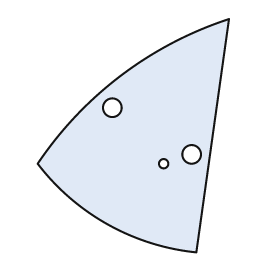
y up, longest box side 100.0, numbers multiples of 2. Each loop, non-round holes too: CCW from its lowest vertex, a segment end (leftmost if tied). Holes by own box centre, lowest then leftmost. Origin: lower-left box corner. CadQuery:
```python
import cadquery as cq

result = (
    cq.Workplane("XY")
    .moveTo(68.0, 0.0)
    .lineTo(82.0, 100.0)
    .threePointArc((36.0, 76.0), (0.0, 38.0))
    .threePointArc((30.0, 12.0), (68.0, 0.0))
    .close()
    .moveTo(54.0, 38.0)
    .circle(2.0)
    .moveTo(66.0, 42.0)
    .circle(4.0)
    .moveTo(32.0, 62.0)
    .circle(4.0)
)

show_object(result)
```